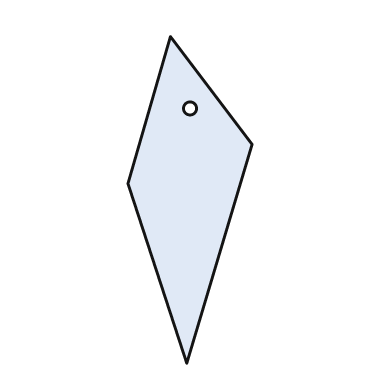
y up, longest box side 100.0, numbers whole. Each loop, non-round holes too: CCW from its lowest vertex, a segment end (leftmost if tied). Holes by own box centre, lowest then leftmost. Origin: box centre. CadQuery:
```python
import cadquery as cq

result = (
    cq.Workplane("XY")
    .moveTo(-1.0, -50.0)
    .lineTo(19.0, 17.0)
    .lineTo(-6.0, 50.0)
    .lineTo(-19.0, 5.0)
    .close()
    .moveTo(0.0, 28.0)
    .circle(2.0)
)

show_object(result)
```